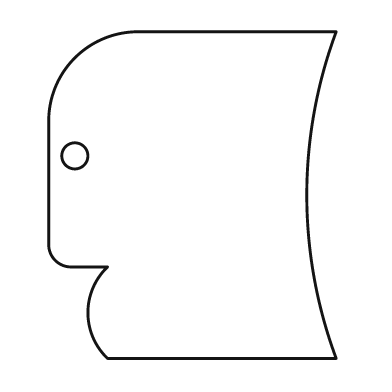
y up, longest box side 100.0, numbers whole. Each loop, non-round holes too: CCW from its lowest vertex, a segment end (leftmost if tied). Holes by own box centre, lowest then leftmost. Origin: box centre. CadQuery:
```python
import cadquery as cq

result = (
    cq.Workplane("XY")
    .moveTo(-26.0, -50.0)
    .lineTo(44.0, -50.0)
    .threePointArc((35.0, 0.0), (44.0, 50.0))
    .lineTo(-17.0, 50.0)
    .threePointArc((-36.0, 42.0), (-44.0, 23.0))
    .lineTo(-44.0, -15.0)
    .threePointArc((-42.0, -20.0), (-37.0, -22.0))
    .lineTo(-26.0, -22.0)
    .threePointArc((-32.0, -36.0), (-26.0, -50.0))
    .close()
    .moveTo(-36.0, 12.0)
    .circle(4.0)
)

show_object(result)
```